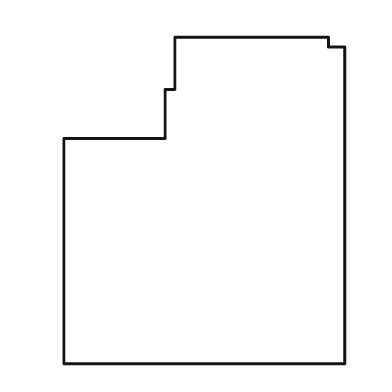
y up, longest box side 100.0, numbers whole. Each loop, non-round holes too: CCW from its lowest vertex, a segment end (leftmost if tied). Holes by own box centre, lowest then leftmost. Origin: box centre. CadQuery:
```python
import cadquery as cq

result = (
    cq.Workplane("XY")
    .moveTo(-43.0, -50.0)
    .lineTo(43.0, -50.0)
    .lineTo(43.0, 47.0)
    .lineTo(38.0, 47.0)
    .lineTo(38.0, 50.0)
    .lineTo(-9.0, 50.0)
    .lineTo(-9.0, 34.0)
    .lineTo(-12.0, 34.0)
    .lineTo(-12.0, 19.0)
    .lineTo(-43.0, 19.0)
    .close()
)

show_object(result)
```